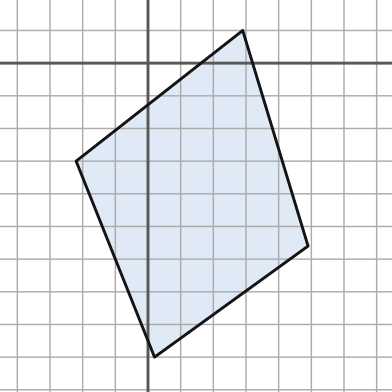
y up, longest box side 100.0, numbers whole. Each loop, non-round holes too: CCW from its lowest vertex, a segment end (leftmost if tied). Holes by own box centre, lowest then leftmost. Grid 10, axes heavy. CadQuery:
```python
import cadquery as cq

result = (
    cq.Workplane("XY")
    .moveTo(2.0, -90.0)
    .lineTo(49.0, -56.0)
    .lineTo(29.0, 10.0)
    .lineTo(-22.0, -30.0)
    .close()
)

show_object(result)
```